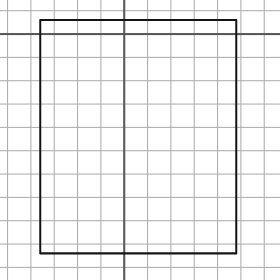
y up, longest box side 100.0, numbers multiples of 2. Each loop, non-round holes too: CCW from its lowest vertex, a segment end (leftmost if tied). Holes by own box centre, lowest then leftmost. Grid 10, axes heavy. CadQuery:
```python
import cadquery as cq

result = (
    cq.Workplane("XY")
    .moveTo(-36.0, -94.0)
    .lineTo(48.0, -94.0)
    .lineTo(48.0, 6.0)
    .lineTo(-36.0, 6.0)
    .close()
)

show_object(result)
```